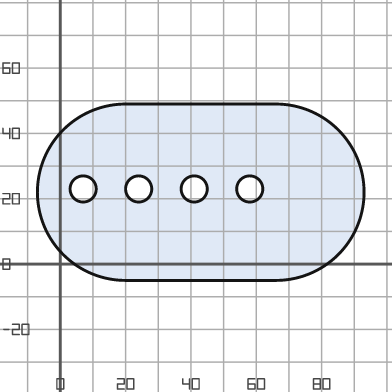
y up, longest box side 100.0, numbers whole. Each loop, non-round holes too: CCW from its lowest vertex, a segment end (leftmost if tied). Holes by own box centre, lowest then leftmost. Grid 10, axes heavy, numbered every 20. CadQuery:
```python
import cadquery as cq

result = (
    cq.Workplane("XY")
    .moveTo(20.0, -5.0)
    .lineTo(66.0, -5.0)
    .threePointArc((93.0, 22.0), (66.0, 49.0))
    .lineTo(20.0, 49.0)
    .threePointArc((-7.0, 22.0), (20.0, -5.0))
    .close()
    .moveTo(7.0, 23.0)
    .circle(4.0)
    .moveTo(24.0, 23.0)
    .circle(4.0)
    .moveTo(41.0, 23.0)
    .circle(4.0)
    .moveTo(58.0, 23.0)
    .circle(4.0)
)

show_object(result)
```